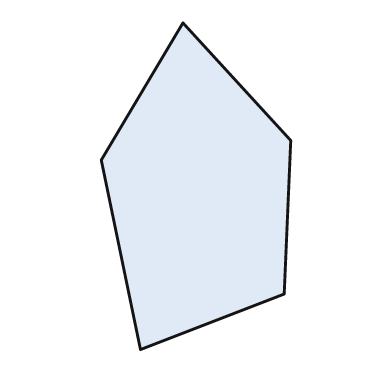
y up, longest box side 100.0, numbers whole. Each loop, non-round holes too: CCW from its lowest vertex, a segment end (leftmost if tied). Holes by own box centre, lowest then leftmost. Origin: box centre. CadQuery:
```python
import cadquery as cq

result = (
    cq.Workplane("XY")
    .moveTo(-17.0, -50.0)
    .lineTo(27.0, -33.0)
    .lineTo(29.0, 14.0)
    .lineTo(-4.0, 50.0)
    .lineTo(-29.0, 8.0)
    .close()
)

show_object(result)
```